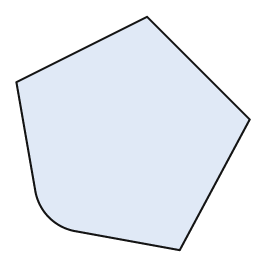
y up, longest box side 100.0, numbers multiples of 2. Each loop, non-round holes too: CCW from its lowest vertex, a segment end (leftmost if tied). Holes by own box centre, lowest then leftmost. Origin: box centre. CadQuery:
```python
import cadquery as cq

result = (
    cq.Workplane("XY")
    .moveTo(20.0, -50.0)
    .lineTo(50.0, 6.0)
    .lineTo(6.0, 50.0)
    .lineTo(-50.0, 22.0)
    .lineTo(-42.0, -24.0)
    .threePointArc((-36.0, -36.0), (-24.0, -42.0))
    .close()
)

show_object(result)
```